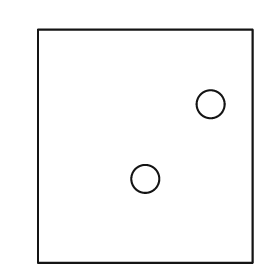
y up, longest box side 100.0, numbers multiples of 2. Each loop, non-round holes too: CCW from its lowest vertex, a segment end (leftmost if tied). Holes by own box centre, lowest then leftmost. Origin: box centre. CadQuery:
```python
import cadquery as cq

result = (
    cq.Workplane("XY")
    .moveTo(-46.0, -50.0)
    .lineTo(46.0, -50.0)
    .lineTo(46.0, 50.0)
    .lineTo(-46.0, 50.0)
    .close()
    .moveTo(0.0, -14.0)
    .circle(6.0)
    .moveTo(28.0, 18.0)
    .circle(6.0)
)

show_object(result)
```